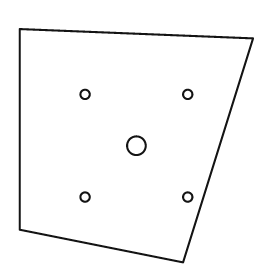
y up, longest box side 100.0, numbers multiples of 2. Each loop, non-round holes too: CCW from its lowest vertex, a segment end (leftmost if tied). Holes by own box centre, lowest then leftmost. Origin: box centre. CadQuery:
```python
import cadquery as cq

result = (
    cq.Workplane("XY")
    .moveTo(20.0, -50.0)
    .lineTo(50.0, 46.0)
    .lineTo(-50.0, 50.0)
    .lineTo(-50.0, -36.0)
    .close()
    .moveTo(-22.0, -22.0)
    .circle(2.0)
    .moveTo(22.0, -22.0)
    .circle(2.0)
    .moveTo(0.0, 0.0)
    .circle(4.0)
    .moveTo(-22.0, 22.0)
    .circle(2.0)
    .moveTo(22.0, 22.0)
    .circle(2.0)
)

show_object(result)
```